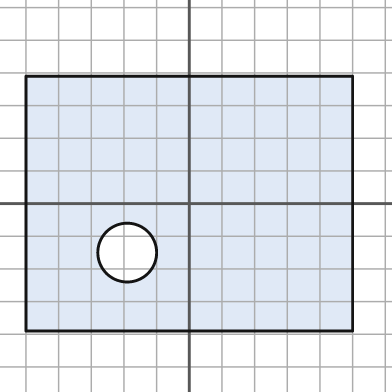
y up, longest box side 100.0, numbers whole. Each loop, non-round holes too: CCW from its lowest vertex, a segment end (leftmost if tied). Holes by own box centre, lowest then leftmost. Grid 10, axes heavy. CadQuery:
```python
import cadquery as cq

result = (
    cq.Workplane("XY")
    .moveTo(-50.0, -39.0)
    .lineTo(50.0, -39.0)
    .lineTo(50.0, 39.0)
    .lineTo(-50.0, 39.0)
    .close()
    .moveTo(-19.0, -15.0)
    .circle(9.0)
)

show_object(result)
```